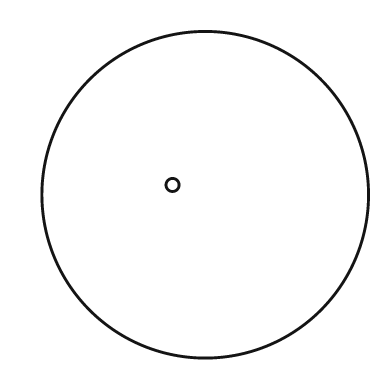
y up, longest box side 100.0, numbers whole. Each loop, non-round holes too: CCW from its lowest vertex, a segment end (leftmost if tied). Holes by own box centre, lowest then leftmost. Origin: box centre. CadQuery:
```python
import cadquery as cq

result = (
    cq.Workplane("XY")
    .moveTo(0.0, 0.0)
    .circle(50.0)
    .moveTo(-10.0, 3.0)
    .circle(2.0)
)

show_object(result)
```